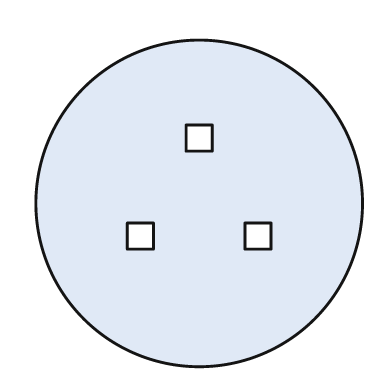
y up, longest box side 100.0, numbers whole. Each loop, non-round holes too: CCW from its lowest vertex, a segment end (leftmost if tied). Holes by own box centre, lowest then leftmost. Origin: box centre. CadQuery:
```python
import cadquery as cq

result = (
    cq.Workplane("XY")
    .moveTo(0.0, 0.0)
    .circle(50.0)
    .moveTo(-22.0, -14.0)
    .lineTo(-14.0, -14.0)
    .lineTo(-14.0, -6.0)
    .lineTo(-22.0, -6.0)
    .close()
    .moveTo(14.0, -14.0)
    .lineTo(22.0, -14.0)
    .lineTo(22.0, -6.0)
    .lineTo(14.0, -6.0)
    .close()
    .moveTo(-4.0, 16.0)
    .lineTo(4.0, 16.0)
    .lineTo(4.0, 24.0)
    .lineTo(-4.0, 24.0)
    .close()
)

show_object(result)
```